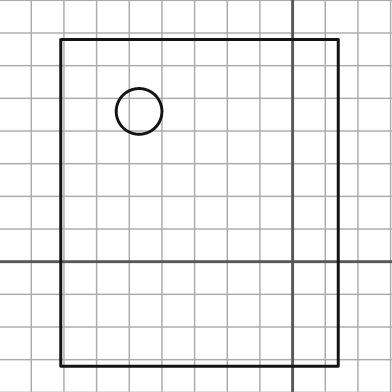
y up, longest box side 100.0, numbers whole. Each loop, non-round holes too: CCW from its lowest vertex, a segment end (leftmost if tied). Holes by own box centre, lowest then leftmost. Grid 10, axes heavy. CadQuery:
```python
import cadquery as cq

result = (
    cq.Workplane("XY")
    .moveTo(-71.0, -32.0)
    .lineTo(14.0, -32.0)
    .lineTo(14.0, 68.0)
    .lineTo(-71.0, 68.0)
    .close()
    .moveTo(-47.0, 46.0)
    .circle(7.0)
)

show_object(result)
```